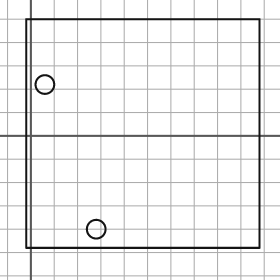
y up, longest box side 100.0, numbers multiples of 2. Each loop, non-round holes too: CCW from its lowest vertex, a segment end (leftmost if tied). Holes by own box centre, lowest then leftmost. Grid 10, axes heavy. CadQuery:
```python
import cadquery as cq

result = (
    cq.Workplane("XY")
    .moveTo(-2.0, -48.0)
    .lineTo(98.0, -48.0)
    .lineTo(98.0, 50.0)
    .lineTo(-2.0, 50.0)
    .close()
    .moveTo(28.0, -40.0)
    .circle(4.0)
    .moveTo(6.0, 22.0)
    .circle(4.0)
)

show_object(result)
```